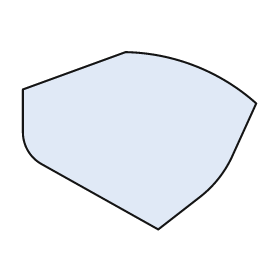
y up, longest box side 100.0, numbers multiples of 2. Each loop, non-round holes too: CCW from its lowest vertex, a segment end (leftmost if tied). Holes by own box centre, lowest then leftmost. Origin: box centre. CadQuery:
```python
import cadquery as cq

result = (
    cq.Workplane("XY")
    .moveTo(8.0, -38.0)
    .lineTo(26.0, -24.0)
    .threePointArc((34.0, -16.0), (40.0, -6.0))
    .lineTo(50.0, 16.0)
    .threePointArc((24.0, 32.0), (-6.0, 38.0))
    .lineTo(-50.0, 22.0)
    .lineTo(-50.0, 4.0)
    .threePointArc((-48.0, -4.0), (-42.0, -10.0))
    .close()
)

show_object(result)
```